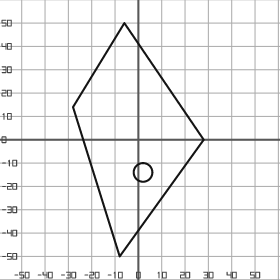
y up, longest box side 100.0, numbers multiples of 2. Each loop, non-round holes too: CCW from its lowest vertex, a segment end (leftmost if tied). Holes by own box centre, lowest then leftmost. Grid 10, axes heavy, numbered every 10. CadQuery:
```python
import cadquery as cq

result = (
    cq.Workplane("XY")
    .moveTo(-8.0, -50.0)
    .lineTo(28.0, 0.0)
    .lineTo(-6.0, 50.0)
    .lineTo(-28.0, 14.0)
    .close()
    .moveTo(2.0, -14.0)
    .circle(4.0)
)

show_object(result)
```